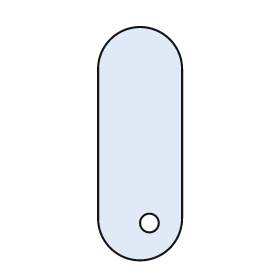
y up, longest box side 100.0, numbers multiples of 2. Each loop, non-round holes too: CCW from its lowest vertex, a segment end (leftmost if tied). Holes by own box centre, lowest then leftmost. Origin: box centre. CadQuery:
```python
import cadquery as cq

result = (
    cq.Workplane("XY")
    .moveTo(-18.0, -32.0)
    .threePointArc((0.0, -50.0), (18.0, -32.0))
    .lineTo(18.0, 32.0)
    .threePointArc((0.0, 50.0), (-18.0, 32.0))
    .close()
    .moveTo(4.0, -34.0)
    .circle(4.0)
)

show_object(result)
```